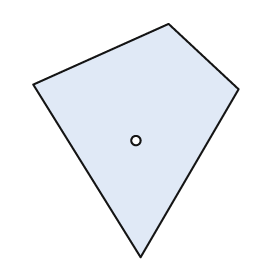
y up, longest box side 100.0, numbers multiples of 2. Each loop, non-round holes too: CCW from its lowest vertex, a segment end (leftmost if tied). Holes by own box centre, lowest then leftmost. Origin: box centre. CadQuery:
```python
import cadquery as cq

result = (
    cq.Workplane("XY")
    .moveTo(2.0, -50.0)
    .lineTo(44.0, 22.0)
    .lineTo(14.0, 50.0)
    .lineTo(-44.0, 24.0)
    .close()
    .moveTo(0.0, 0.0)
    .circle(2.0)
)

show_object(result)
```